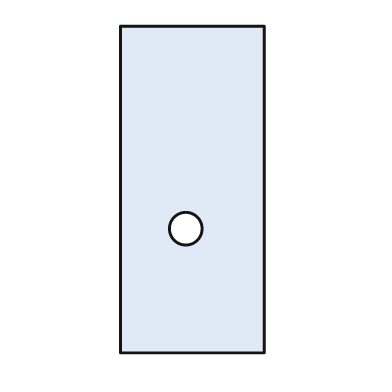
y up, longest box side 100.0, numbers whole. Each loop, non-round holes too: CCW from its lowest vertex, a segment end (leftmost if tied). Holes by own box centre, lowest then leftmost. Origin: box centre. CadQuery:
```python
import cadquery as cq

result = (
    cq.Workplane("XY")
    .moveTo(-22.0, -50.0)
    .lineTo(22.0, -50.0)
    .lineTo(22.0, 50.0)
    .lineTo(-22.0, 50.0)
    .close()
    .moveTo(-2.0, -12.0)
    .circle(5.0)
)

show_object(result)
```